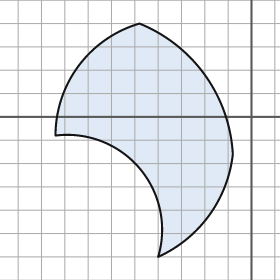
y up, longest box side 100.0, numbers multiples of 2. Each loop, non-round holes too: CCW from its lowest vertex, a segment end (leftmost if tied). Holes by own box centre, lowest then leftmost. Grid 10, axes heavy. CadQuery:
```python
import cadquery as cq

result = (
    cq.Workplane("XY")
    .moveTo(-40.0, -60.0)
    .threePointArc((-18.0, -42.0), (-8.0, -16.0))
    .threePointArc((-20.0, 18.0), (-48.0, 40.0))
    .threePointArc((-74.0, 22.0), (-84.0, -8.0))
    .threePointArc((-48.0, -22.0), (-40.0, -60.0))
    .close()
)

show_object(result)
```